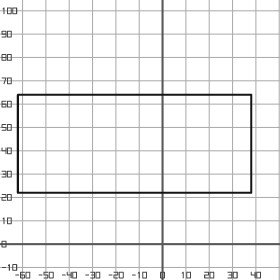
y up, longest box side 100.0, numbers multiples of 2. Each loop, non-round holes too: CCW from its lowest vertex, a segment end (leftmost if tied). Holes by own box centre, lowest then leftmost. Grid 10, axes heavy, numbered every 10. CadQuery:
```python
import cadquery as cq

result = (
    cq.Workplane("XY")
    .moveTo(-62.0, 22.0)
    .lineTo(38.0, 22.0)
    .lineTo(38.0, 64.0)
    .lineTo(-62.0, 64.0)
    .close()
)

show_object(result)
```